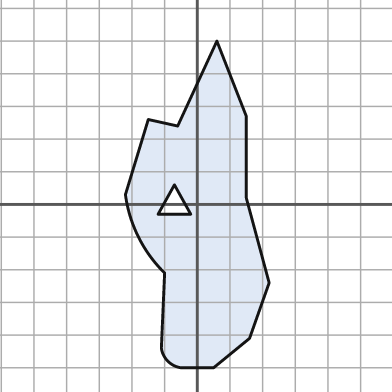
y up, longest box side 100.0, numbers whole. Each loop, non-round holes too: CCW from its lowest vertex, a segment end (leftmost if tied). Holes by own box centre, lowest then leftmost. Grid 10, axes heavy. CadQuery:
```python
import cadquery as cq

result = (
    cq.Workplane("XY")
    .moveTo(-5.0, -50.0)
    .lineTo(5.0, -50.0)
    .lineTo(16.0, -41.0)
    .lineTo(22.0, -24.0)
    .lineTo(15.0, 2.0)
    .lineTo(15.0, 27.0)
    .lineTo(6.0, 50.0)
    .lineTo(-6.0, 24.0)
    .lineTo(-15.0, 26.0)
    .lineTo(-22.0, 3.0)
    .threePointArc((-18.0, -10.0), (-10.0, -21.0))
    .lineTo(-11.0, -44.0)
    .threePointArc((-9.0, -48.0), (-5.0, -50.0))
    .close()
    .moveTo(-12.0, -3.0)
    .lineTo(-2.0, -3.0)
    .lineTo(-7.0, 6.0)
    .close()
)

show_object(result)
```